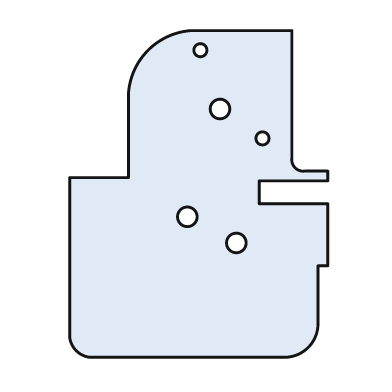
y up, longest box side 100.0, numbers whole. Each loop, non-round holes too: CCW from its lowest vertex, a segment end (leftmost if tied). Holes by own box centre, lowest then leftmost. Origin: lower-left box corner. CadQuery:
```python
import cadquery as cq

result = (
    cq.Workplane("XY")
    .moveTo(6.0, 0.0)
    .lineTo(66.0, 0.0)
    .threePointArc((73.0, 3.0), (76.0, 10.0))
    .lineTo(76.0, 28.0)
    .lineTo(79.0, 28.0)
    .lineTo(79.0, 47.0)
    .lineTo(58.0, 47.0)
    .lineTo(58.0, 54.0)
    .lineTo(79.0, 54.0)
    .lineTo(79.0, 57.0)
    .lineTo(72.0, 57.0)
    .threePointArc((69.0, 58.0), (68.0, 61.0))
    .lineTo(68.0, 100.0)
    .lineTo(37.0, 100.0)
    .threePointArc((24.0, 94.0), (18.0, 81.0))
    .lineTo(18.0, 55.0)
    .lineTo(0.0, 55.0)
    .lineTo(0.0, 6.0)
    .threePointArc((2.0, 2.0), (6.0, 0.0))
    .close()
    .moveTo(51.0, 35.0)
    .circle(3.0)
    .moveTo(36.0, 43.0)
    .circle(3.0)
    .moveTo(59.0, 67.0)
    .circle(2.0)
    .moveTo(46.0, 76.0)
    .circle(3.0)
    .moveTo(40.0, 94.0)
    .circle(2.0)
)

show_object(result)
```